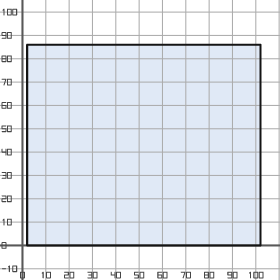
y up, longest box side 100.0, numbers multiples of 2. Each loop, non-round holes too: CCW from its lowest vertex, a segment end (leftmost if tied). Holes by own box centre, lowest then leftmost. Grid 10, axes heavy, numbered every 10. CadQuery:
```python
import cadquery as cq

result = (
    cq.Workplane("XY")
    .moveTo(2.0, 0.0)
    .lineTo(102.0, 0.0)
    .lineTo(102.0, 86.0)
    .lineTo(2.0, 86.0)
    .close()
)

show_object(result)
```